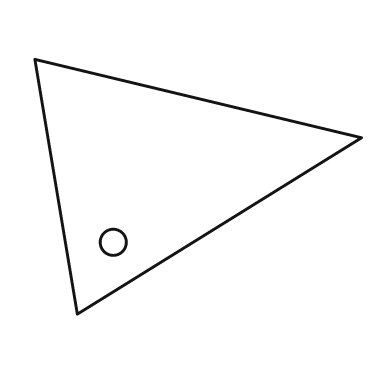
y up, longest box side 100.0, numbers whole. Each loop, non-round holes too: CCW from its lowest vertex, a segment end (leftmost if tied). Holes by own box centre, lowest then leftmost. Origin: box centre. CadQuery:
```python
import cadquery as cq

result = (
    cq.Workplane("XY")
    .moveTo(-37.0, -39.0)
    .lineTo(50.0, 15.0)
    .lineTo(-50.0, 39.0)
    .close()
    .moveTo(-26.0, -17.0)
    .circle(4.0)
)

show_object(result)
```